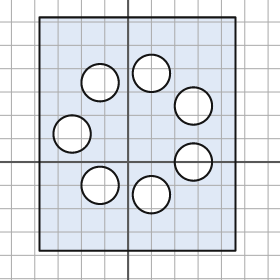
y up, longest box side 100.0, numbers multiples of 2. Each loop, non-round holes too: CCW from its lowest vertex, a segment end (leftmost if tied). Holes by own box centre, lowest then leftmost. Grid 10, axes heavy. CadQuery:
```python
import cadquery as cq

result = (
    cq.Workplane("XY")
    .moveTo(-38.0, -38.0)
    .lineTo(46.0, -38.0)
    .lineTo(46.0, 62.0)
    .lineTo(-38.0, 62.0)
    .close()
    .moveTo(10.0, -14.0)
    .circle(8.0)
    .moveTo(-12.0, -10.0)
    .circle(8.0)
    .moveTo(28.0, 0.0)
    .circle(8.0)
    .moveTo(-24.0, 12.0)
    .circle(8.0)
    .moveTo(28.0, 24.0)
    .circle(8.0)
    .moveTo(-12.0, 34.0)
    .circle(8.0)
    .moveTo(10.0, 38.0)
    .circle(8.0)
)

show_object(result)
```